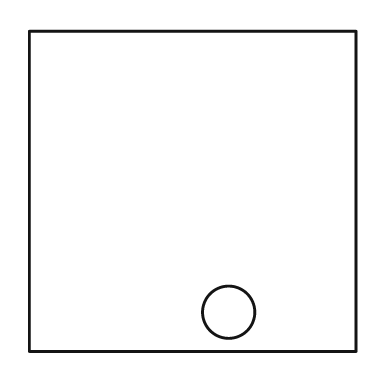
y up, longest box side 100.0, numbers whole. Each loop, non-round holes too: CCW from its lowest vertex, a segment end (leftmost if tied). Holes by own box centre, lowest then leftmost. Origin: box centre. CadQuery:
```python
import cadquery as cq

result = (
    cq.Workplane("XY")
    .moveTo(-50.0, -49.0)
    .lineTo(50.0, -49.0)
    .lineTo(50.0, 49.0)
    .lineTo(-50.0, 49.0)
    .close()
    .moveTo(11.0, -37.0)
    .circle(8.0)
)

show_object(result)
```